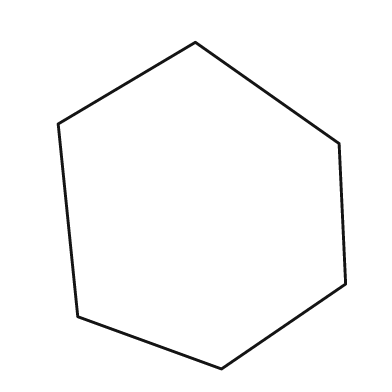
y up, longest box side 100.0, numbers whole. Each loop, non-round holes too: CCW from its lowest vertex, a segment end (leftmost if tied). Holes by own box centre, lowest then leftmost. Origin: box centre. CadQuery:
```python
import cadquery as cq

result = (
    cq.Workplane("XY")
    .moveTo(6.0, -50.0)
    .lineTo(44.0, -24.0)
    .lineTo(42.0, 19.0)
    .lineTo(-2.0, 50.0)
    .lineTo(-44.0, 25.0)
    .lineTo(-38.0, -34.0)
    .close()
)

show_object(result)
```